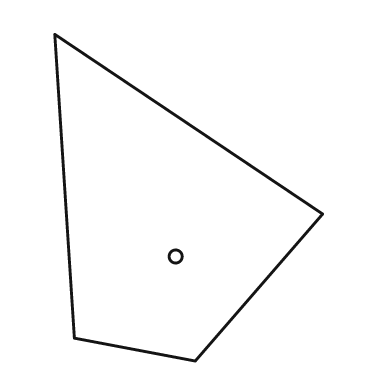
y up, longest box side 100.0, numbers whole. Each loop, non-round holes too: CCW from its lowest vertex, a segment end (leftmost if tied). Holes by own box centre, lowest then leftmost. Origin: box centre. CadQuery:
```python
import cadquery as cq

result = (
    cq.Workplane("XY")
    .moveTo(2.0, -50.0)
    .lineTo(41.0, -5.0)
    .lineTo(-41.0, 50.0)
    .lineTo(-35.0, -43.0)
    .close()
    .moveTo(-4.0, -18.0)
    .circle(2.0)
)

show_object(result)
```